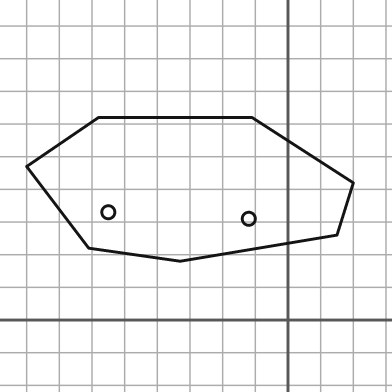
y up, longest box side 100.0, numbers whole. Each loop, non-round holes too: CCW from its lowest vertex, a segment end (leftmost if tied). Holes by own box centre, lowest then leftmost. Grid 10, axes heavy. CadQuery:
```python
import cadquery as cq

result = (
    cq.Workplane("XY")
    .moveTo(-33.0, 18.0)
    .lineTo(15.0, 26.0)
    .lineTo(20.0, 42.0)
    .lineTo(-11.0, 62.0)
    .lineTo(-58.0, 62.0)
    .lineTo(-80.0, 47.0)
    .lineTo(-61.0, 22.0)
    .close()
    .moveTo(-12.0, 31.0)
    .circle(2.0)
    .moveTo(-55.0, 33.0)
    .circle(2.0)
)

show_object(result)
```